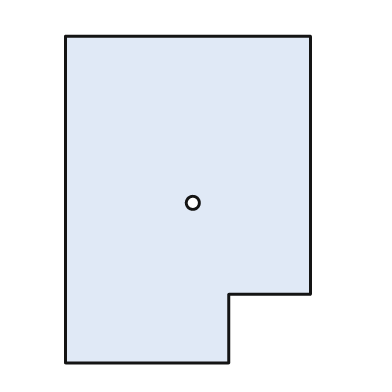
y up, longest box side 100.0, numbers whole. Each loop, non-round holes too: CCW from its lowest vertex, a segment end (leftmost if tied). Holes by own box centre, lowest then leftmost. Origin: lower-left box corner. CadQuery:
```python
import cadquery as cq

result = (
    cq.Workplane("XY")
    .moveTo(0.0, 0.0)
    .lineTo(50.0, 0.0)
    .lineTo(50.0, 21.0)
    .lineTo(75.0, 21.0)
    .lineTo(75.0, 100.0)
    .lineTo(0.0, 100.0)
    .close()
    .moveTo(39.0, 49.0)
    .circle(2.0)
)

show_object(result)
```